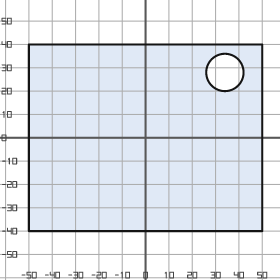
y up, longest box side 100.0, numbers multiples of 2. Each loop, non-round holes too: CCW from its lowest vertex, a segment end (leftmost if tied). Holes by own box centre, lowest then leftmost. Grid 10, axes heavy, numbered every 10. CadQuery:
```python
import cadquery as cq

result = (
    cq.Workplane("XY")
    .moveTo(-50.0, -40.0)
    .lineTo(50.0, -40.0)
    .lineTo(50.0, 40.0)
    .lineTo(-50.0, 40.0)
    .close()
    .moveTo(34.0, 28.0)
    .circle(8.0)
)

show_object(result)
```